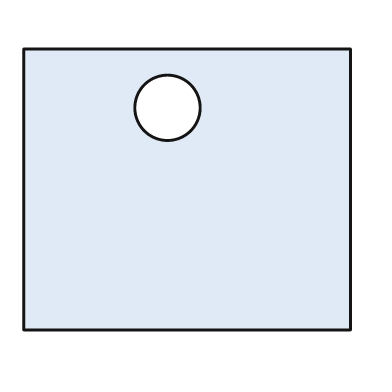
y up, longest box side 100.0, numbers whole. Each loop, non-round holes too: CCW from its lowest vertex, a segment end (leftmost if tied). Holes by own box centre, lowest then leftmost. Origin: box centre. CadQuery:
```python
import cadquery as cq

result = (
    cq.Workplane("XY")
    .moveTo(-50.0, -43.0)
    .lineTo(50.0, -43.0)
    .lineTo(50.0, 43.0)
    .lineTo(-50.0, 43.0)
    .close()
    .moveTo(-6.0, 25.0)
    .circle(10.0)
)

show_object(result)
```